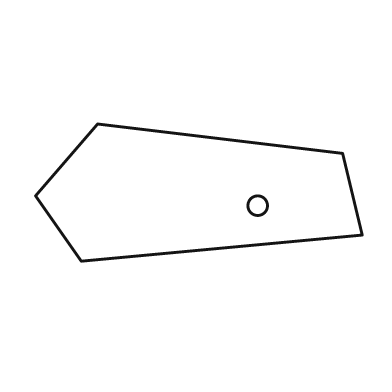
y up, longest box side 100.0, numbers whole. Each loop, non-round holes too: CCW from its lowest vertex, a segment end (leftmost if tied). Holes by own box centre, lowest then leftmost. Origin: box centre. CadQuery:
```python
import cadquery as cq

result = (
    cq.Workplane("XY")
    .moveTo(-36.0, -21.0)
    .lineTo(50.0, -13.0)
    .lineTo(44.0, 12.0)
    .lineTo(-31.0, 21.0)
    .lineTo(-50.0, -1.0)
    .close()
    .moveTo(18.0, -4.0)
    .circle(3.0)
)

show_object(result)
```